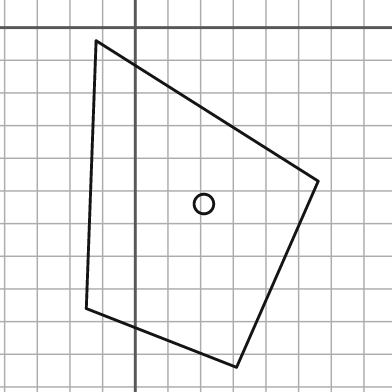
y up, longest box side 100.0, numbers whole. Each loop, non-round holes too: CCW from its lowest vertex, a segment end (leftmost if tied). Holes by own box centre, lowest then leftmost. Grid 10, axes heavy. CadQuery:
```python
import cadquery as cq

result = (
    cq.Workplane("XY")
    .moveTo(31.0, -104.0)
    .lineTo(56.0, -47.0)
    .lineTo(-12.0, -4.0)
    .lineTo(-15.0, -86.0)
    .close()
    .moveTo(21.0, -54.0)
    .circle(3.0)
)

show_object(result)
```